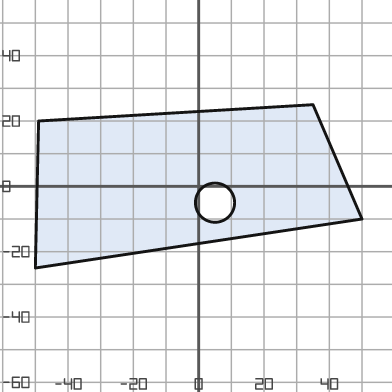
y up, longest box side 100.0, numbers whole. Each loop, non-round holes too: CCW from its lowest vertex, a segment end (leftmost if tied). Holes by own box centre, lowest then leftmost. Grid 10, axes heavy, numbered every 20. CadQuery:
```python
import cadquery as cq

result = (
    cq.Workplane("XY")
    .moveTo(-50.0, -25.0)
    .lineTo(50.0, -10.0)
    .lineTo(35.0, 25.0)
    .lineTo(-49.0, 20.0)
    .close()
    .moveTo(5.0, -5.0)
    .circle(6.0)
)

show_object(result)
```